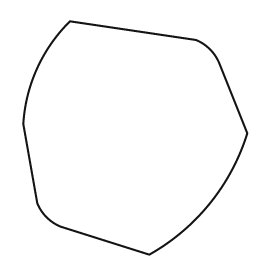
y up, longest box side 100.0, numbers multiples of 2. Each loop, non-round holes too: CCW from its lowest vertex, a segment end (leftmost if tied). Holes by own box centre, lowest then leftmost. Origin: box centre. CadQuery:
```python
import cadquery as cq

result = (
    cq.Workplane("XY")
    .moveTo(6.0, -50.0)
    .threePointArc((32.0, -28.0), (48.0, 2.0))
    .lineTo(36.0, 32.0)
    .threePointArc((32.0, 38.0), (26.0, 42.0))
    .lineTo(-28.0, 50.0)
    .threePointArc((-42.0, 30.0), (-48.0, 6.0))
    .lineTo(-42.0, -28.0)
    .threePointArc((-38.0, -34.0), (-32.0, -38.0))
    .close()
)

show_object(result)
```